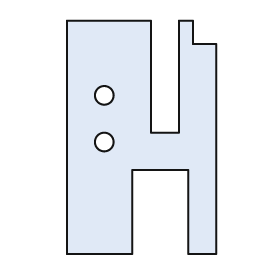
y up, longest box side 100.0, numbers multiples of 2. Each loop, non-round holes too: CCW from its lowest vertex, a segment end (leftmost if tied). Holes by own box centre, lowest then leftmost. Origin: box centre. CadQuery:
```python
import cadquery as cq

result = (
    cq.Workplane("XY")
    .moveTo(-32.0, -50.0)
    .lineTo(-4.0, -50.0)
    .lineTo(-4.0, -14.0)
    .lineTo(20.0, -14.0)
    .lineTo(20.0, -50.0)
    .lineTo(32.0, -50.0)
    .lineTo(32.0, 40.0)
    .lineTo(22.0, 40.0)
    .lineTo(22.0, 50.0)
    .lineTo(16.0, 50.0)
    .lineTo(16.0, 2.0)
    .lineTo(4.0, 2.0)
    .lineTo(4.0, 50.0)
    .lineTo(-32.0, 50.0)
    .close()
    .moveTo(-16.0, -2.0)
    .circle(4.0)
    .moveTo(-16.0, 18.0)
    .circle(4.0)
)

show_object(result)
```